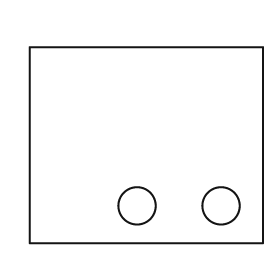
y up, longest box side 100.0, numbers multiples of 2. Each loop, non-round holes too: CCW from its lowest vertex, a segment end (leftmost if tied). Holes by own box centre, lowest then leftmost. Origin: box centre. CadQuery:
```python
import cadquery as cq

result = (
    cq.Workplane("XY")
    .moveTo(-50.0, -42.0)
    .lineTo(50.0, -42.0)
    .lineTo(50.0, 42.0)
    .lineTo(-50.0, 42.0)
    .close()
    .moveTo(-4.0, -26.0)
    .circle(8.0)
    .moveTo(32.0, -26.0)
    .circle(8.0)
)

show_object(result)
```